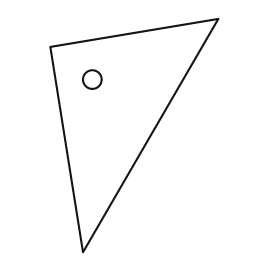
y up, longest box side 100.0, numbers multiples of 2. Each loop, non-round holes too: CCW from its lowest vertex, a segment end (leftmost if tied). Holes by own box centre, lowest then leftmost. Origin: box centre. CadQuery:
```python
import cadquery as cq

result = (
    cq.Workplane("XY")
    .moveTo(-22.0, -50.0)
    .lineTo(36.0, 50.0)
    .lineTo(-36.0, 38.0)
    .close()
    .moveTo(-18.0, 24.0)
    .circle(4.0)
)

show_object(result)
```